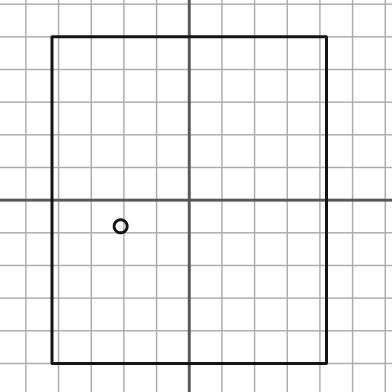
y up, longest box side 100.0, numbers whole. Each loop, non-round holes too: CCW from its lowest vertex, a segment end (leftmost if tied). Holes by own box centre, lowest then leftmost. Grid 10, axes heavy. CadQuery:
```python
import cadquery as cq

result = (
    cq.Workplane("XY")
    .moveTo(-42.0, -50.0)
    .lineTo(42.0, -50.0)
    .lineTo(42.0, 50.0)
    .lineTo(-42.0, 50.0)
    .close()
    .moveTo(-21.0, -8.0)
    .circle(2.0)
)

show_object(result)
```